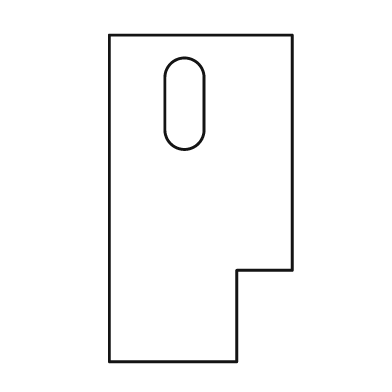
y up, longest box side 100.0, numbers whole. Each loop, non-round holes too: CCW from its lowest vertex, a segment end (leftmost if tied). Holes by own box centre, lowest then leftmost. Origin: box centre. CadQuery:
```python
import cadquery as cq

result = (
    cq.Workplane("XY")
    .moveTo(-28.0, -50.0)
    .lineTo(11.0, -50.0)
    .lineTo(11.0, -22.0)
    .lineTo(28.0, -22.0)
    .lineTo(28.0, 50.0)
    .lineTo(-28.0, 50.0)
    .close()
    .moveTo(-11.0, 21.0)
    .threePointArc((-5.0, 15.0), (1.0, 21.0))
    .lineTo(1.0, 37.0)
    .threePointArc((-5.0, 43.0), (-11.0, 37.0))
    .close()
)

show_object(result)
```